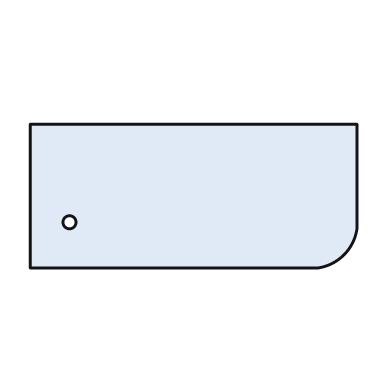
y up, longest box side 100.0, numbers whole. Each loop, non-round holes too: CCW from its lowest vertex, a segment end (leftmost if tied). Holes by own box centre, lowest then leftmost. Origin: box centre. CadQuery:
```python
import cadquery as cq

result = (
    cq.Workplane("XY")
    .moveTo(-50.0, -22.0)
    .lineTo(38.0, -22.0)
    .threePointArc((46.0, -18.0), (50.0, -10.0))
    .lineTo(50.0, 22.0)
    .lineTo(-50.0, 22.0)
    .close()
    .moveTo(-38.0, -8.0)
    .circle(2.0)
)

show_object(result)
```